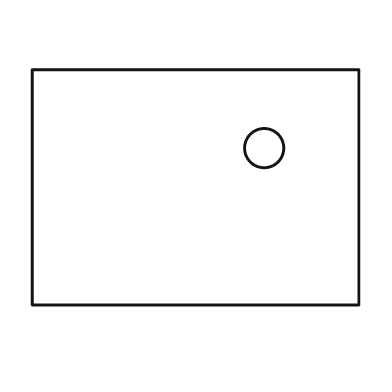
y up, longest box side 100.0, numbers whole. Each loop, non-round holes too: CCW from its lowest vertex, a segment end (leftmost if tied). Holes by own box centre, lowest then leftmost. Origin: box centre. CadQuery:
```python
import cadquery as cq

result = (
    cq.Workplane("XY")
    .moveTo(-50.0, -36.0)
    .lineTo(50.0, -36.0)
    .lineTo(50.0, 36.0)
    .lineTo(-50.0, 36.0)
    .close()
    .moveTo(21.0, 12.0)
    .circle(6.0)
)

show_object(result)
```